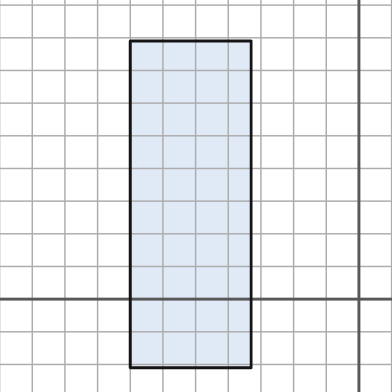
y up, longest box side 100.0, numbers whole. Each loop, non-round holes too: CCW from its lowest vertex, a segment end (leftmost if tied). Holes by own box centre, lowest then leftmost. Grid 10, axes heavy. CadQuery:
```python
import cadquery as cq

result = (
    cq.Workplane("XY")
    .moveTo(-70.0, -21.0)
    .lineTo(-33.0, -21.0)
    .lineTo(-33.0, 79.0)
    .lineTo(-70.0, 79.0)
    .close()
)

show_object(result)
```